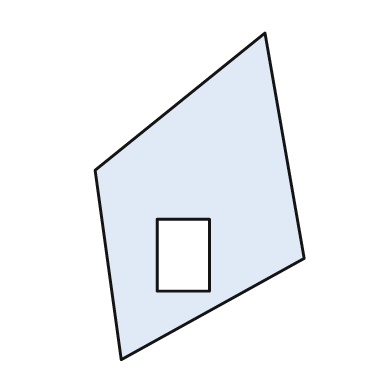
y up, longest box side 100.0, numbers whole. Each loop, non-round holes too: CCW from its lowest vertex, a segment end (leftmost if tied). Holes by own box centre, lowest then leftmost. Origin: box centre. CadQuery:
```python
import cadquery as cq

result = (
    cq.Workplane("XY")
    .moveTo(-24.0, -50.0)
    .lineTo(32.0, -19.0)
    .lineTo(20.0, 50.0)
    .lineTo(-32.0, 8.0)
    .close()
    .moveTo(-13.0, -29.0)
    .lineTo(3.0, -29.0)
    .lineTo(3.0, -7.0)
    .lineTo(-13.0, -7.0)
    .close()
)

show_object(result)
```